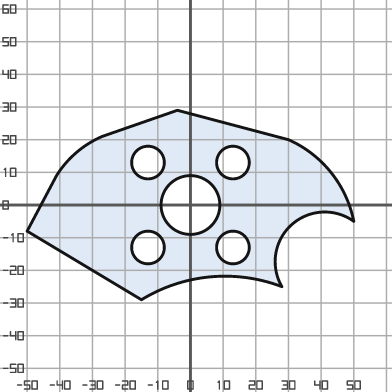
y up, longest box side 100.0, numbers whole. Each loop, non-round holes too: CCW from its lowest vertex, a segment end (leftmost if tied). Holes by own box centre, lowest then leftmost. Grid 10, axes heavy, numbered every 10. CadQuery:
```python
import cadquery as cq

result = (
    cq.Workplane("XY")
    .moveTo(-15.0, -29.0)
    .threePointArc((6.0, -22.0), (28.0, -25.0))
    .threePointArc((31.0, -6.0), (50.0, -5.0))
    .threePointArc((43.0, 10.0), (30.0, 20.0))
    .lineTo(-4.0, 29.0)
    .lineTo(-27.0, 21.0)
    .threePointArc((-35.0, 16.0), (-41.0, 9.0))
    .lineTo(-50.0, -8.0)
    .close()
    .moveTo(-13.0, -13.0)
    .circle(5.0)
    .moveTo(13.0, -13.0)
    .circle(5.0)
    .moveTo(0.0, 0.0)
    .circle(9.0)
    .moveTo(-13.0, 13.0)
    .circle(5.0)
    .moveTo(13.0, 13.0)
    .circle(5.0)
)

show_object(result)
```